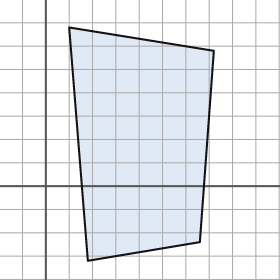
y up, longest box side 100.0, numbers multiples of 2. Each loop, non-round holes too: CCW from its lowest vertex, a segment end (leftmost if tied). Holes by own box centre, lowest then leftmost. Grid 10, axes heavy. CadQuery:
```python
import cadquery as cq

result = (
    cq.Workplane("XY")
    .moveTo(18.0, -32.0)
    .lineTo(66.0, -24.0)
    .lineTo(72.0, 58.0)
    .lineTo(10.0, 68.0)
    .close()
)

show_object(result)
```